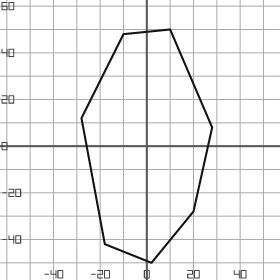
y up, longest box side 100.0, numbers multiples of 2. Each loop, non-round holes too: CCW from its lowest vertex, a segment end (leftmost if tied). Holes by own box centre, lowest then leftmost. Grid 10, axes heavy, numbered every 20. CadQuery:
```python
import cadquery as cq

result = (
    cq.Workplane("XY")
    .moveTo(2.0, -50.0)
    .lineTo(20.0, -28.0)
    .lineTo(28.0, 8.0)
    .lineTo(10.0, 50.0)
    .lineTo(-10.0, 48.0)
    .lineTo(-28.0, 12.0)
    .lineTo(-18.0, -42.0)
    .close()
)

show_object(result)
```